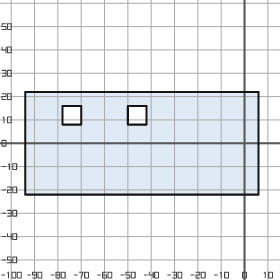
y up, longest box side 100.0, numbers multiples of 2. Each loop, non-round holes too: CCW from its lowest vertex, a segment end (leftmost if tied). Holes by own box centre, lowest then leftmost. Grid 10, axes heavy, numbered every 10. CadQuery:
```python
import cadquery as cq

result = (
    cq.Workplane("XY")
    .moveTo(-94.0, -22.0)
    .lineTo(6.0, -22.0)
    .lineTo(6.0, 22.0)
    .lineTo(-94.0, 22.0)
    .close()
    .moveTo(-78.0, 8.0)
    .lineTo(-70.0, 8.0)
    .lineTo(-70.0, 16.0)
    .lineTo(-78.0, 16.0)
    .close()
    .moveTo(-50.0, 8.0)
    .lineTo(-42.0, 8.0)
    .lineTo(-42.0, 16.0)
    .lineTo(-50.0, 16.0)
    .close()
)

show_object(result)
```